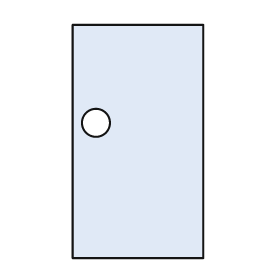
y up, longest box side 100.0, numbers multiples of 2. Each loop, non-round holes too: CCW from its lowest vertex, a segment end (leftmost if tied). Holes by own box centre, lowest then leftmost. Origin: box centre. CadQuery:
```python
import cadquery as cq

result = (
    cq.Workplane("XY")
    .moveTo(-28.0, -50.0)
    .lineTo(28.0, -50.0)
    .lineTo(28.0, 50.0)
    .lineTo(-28.0, 50.0)
    .close()
    .moveTo(-18.0, 8.0)
    .circle(6.0)
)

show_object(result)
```